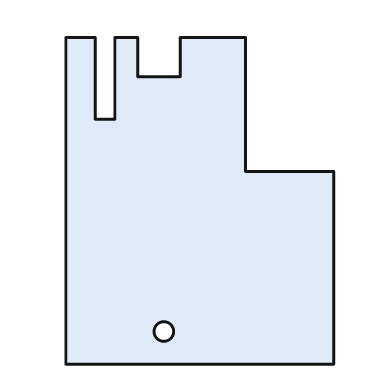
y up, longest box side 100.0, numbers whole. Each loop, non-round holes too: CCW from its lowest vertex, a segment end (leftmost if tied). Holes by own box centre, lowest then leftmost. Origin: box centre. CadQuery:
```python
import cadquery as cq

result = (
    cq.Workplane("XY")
    .moveTo(-41.0, -50.0)
    .lineTo(41.0, -50.0)
    .lineTo(41.0, 9.0)
    .lineTo(14.0, 9.0)
    .lineTo(14.0, 50.0)
    .lineTo(-6.0, 50.0)
    .lineTo(-6.0, 38.0)
    .lineTo(-19.0, 38.0)
    .lineTo(-19.0, 50.0)
    .lineTo(-26.0, 50.0)
    .lineTo(-26.0, 25.0)
    .lineTo(-32.0, 25.0)
    .lineTo(-32.0, 50.0)
    .lineTo(-41.0, 50.0)
    .close()
    .moveTo(-11.0, -40.0)
    .circle(3.0)
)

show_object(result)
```